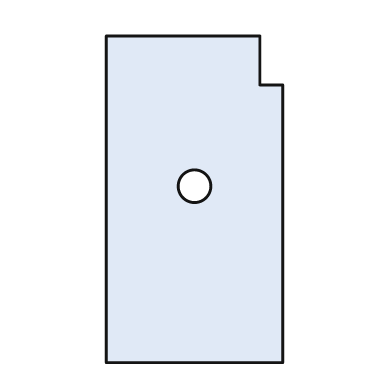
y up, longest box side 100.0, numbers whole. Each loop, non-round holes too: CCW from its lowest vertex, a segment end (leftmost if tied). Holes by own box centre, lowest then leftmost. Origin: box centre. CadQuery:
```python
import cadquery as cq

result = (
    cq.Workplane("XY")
    .moveTo(-27.0, -50.0)
    .lineTo(27.0, -50.0)
    .lineTo(27.0, 35.0)
    .lineTo(20.0, 35.0)
    .lineTo(20.0, 50.0)
    .lineTo(-27.0, 50.0)
    .close()
    .moveTo(0.0, 4.0)
    .circle(5.0)
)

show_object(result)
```